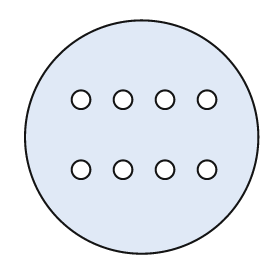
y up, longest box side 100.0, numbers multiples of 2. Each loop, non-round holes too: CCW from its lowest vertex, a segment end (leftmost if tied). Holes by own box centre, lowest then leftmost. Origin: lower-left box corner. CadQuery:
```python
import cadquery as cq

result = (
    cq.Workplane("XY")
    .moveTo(50.0, 50.0)
    .circle(50.0)
    .moveTo(24.0, 36.0)
    .circle(4.0)
    .moveTo(42.0, 36.0)
    .circle(4.0)
    .moveTo(60.0, 36.0)
    .circle(4.0)
    .moveTo(78.0, 36.0)
    .circle(4.0)
    .moveTo(24.0, 66.0)
    .circle(4.0)
    .moveTo(42.0, 66.0)
    .circle(4.0)
    .moveTo(60.0, 66.0)
    .circle(4.0)
    .moveTo(78.0, 66.0)
    .circle(4.0)
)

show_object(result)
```